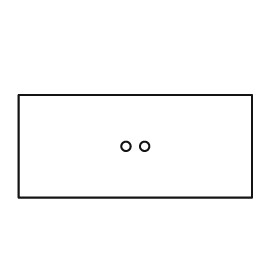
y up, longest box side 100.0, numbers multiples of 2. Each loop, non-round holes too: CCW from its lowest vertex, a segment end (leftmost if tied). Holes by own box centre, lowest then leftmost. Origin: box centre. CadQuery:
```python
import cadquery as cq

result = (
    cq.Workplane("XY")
    .moveTo(-50.0, -22.0)
    .lineTo(50.0, -22.0)
    .lineTo(50.0, 22.0)
    .lineTo(-50.0, 22.0)
    .close()
    .moveTo(-4.0, 0.0)
    .circle(2.0)
    .moveTo(4.0, 0.0)
    .circle(2.0)
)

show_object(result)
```